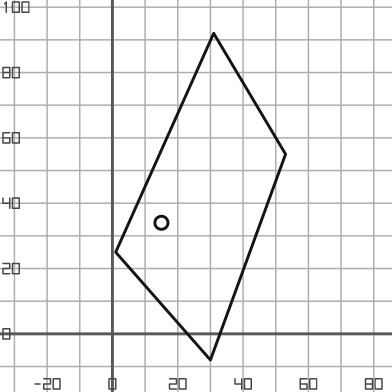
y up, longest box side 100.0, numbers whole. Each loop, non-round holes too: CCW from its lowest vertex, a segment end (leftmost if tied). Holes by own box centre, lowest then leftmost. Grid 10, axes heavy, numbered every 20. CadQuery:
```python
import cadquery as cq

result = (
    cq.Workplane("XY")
    .moveTo(30.0, -8.0)
    .lineTo(53.0, 55.0)
    .lineTo(31.0, 92.0)
    .lineTo(1.0, 25.0)
    .close()
    .moveTo(15.0, 34.0)
    .circle(2.0)
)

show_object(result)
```